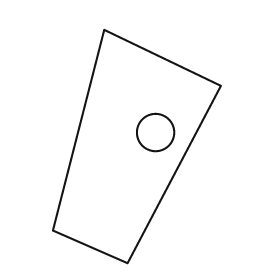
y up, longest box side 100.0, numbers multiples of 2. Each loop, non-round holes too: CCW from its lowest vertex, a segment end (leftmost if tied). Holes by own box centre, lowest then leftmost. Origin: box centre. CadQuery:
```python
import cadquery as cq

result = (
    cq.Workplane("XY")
    .moveTo(-4.0, -50.0)
    .lineTo(36.0, 26.0)
    .lineTo(-14.0, 50.0)
    .lineTo(-36.0, -36.0)
    .close()
    .moveTo(8.0, 6.0)
    .circle(8.0)
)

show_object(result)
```